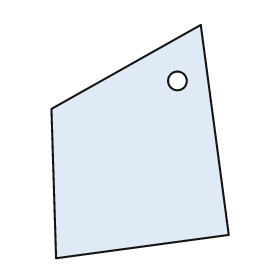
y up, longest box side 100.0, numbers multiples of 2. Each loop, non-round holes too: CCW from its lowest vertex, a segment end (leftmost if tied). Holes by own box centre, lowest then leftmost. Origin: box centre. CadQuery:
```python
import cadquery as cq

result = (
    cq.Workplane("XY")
    .moveTo(-36.0, -50.0)
    .lineTo(38.0, -40.0)
    .lineTo(26.0, 50.0)
    .lineTo(-38.0, 14.0)
    .close()
    .moveTo(16.0, 26.0)
    .circle(4.0)
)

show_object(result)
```